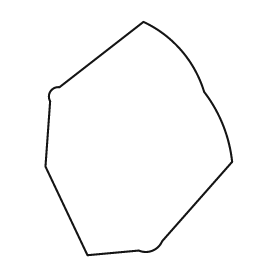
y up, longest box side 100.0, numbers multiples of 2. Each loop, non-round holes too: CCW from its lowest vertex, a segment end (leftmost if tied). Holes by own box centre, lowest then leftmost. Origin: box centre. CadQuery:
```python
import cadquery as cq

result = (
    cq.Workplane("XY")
    .moveTo(-22.0, -50.0)
    .lineTo(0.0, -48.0)
    .threePointArc((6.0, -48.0), (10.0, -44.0))
    .lineTo(40.0, -10.0)
    .threePointArc((36.0, 6.0), (28.0, 20.0))
    .threePointArc((18.0, 38.0), (2.0, 50.0))
    .lineTo(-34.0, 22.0)
    .threePointArc((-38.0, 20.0), (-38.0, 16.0))
    .lineTo(-40.0, -12.0)
    .close()
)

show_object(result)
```